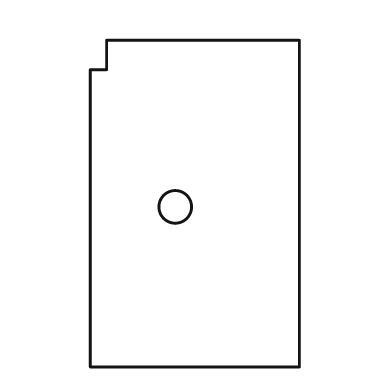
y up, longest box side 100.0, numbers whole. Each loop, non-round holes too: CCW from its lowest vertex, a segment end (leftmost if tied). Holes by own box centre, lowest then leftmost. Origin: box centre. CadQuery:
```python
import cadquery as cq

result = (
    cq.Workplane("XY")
    .moveTo(-32.0, -50.0)
    .lineTo(32.0, -50.0)
    .lineTo(32.0, 50.0)
    .lineTo(-27.0, 50.0)
    .lineTo(-27.0, 41.0)
    .lineTo(-32.0, 41.0)
    .close()
    .moveTo(-6.0, -1.0)
    .circle(5.0)
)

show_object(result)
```